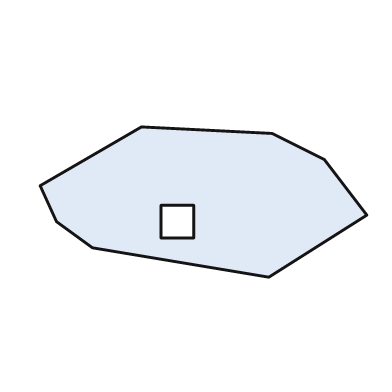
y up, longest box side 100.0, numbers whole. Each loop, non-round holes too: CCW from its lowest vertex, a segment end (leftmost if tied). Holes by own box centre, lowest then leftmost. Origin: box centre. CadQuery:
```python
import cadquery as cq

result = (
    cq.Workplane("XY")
    .moveTo(20.0, -23.0)
    .lineTo(50.0, -4.0)
    .lineTo(37.0, 13.0)
    .lineTo(21.0, 21.0)
    .lineTo(-19.0, 23.0)
    .lineTo(-50.0, 5.0)
    .lineTo(-45.0, -6.0)
    .lineTo(-34.0, -14.0)
    .close()
    .moveTo(-13.0, -11.0)
    .lineTo(-3.0, -11.0)
    .lineTo(-3.0, -1.0)
    .lineTo(-13.0, -1.0)
    .close()
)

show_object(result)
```